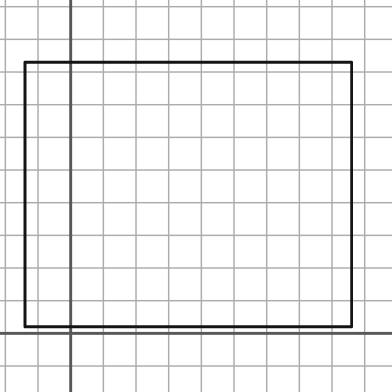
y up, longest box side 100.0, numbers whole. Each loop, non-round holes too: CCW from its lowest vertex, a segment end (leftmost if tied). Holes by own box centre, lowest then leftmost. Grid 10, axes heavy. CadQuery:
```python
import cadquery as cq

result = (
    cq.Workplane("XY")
    .moveTo(-14.0, 2.0)
    .lineTo(86.0, 2.0)
    .lineTo(86.0, 83.0)
    .lineTo(-14.0, 83.0)
    .close()
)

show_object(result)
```